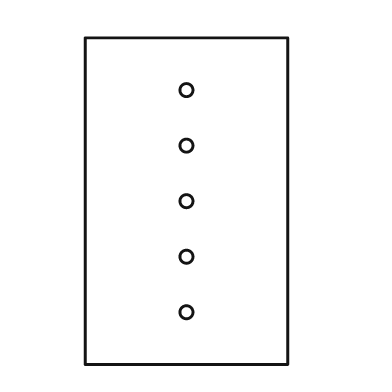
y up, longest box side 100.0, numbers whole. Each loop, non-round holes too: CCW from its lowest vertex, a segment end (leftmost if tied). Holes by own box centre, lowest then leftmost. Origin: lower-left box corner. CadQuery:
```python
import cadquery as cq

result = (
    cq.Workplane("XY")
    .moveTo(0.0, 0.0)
    .lineTo(62.0, 0.0)
    .lineTo(62.0, 100.0)
    .lineTo(0.0, 100.0)
    .close()
    .moveTo(31.0, 16.0)
    .circle(2.0)
    .moveTo(31.0, 33.0)
    .circle(2.0)
    .moveTo(31.0, 50.0)
    .circle(2.0)
    .moveTo(31.0, 67.0)
    .circle(2.0)
    .moveTo(31.0, 84.0)
    .circle(2.0)
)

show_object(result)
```